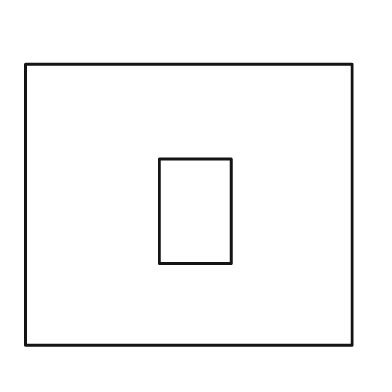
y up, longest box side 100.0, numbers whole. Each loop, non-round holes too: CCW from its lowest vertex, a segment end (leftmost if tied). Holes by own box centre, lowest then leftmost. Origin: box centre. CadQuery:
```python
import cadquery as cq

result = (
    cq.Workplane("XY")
    .moveTo(-50.0, -43.0)
    .lineTo(50.0, -43.0)
    .lineTo(50.0, 43.0)
    .lineTo(-50.0, 43.0)
    .close()
    .moveTo(-9.0, -18.0)
    .lineTo(13.0, -18.0)
    .lineTo(13.0, 14.0)
    .lineTo(-9.0, 14.0)
    .close()
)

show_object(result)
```